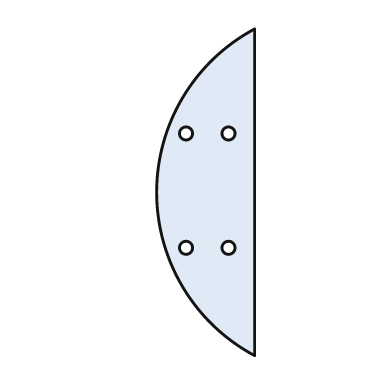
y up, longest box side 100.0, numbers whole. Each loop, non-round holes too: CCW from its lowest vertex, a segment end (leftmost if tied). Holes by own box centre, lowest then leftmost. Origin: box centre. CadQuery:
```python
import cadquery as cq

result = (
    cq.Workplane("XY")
    .moveTo(15.0, -50.0)
    .lineTo(15.0, 50.0)
    .threePointArc((-15.0, 0.0), (15.0, -50.0))
    .close()
    .moveTo(-6.0, -17.0)
    .circle(2.0)
    .moveTo(7.0, -17.0)
    .circle(2.0)
    .moveTo(-6.0, 18.0)
    .circle(2.0)
    .moveTo(7.0, 18.0)
    .circle(2.0)
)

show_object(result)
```